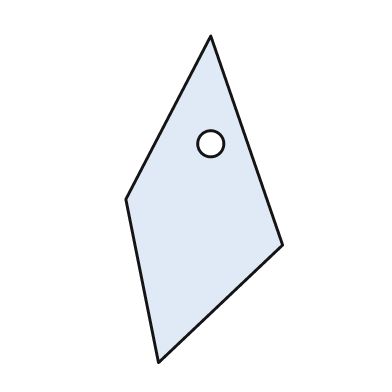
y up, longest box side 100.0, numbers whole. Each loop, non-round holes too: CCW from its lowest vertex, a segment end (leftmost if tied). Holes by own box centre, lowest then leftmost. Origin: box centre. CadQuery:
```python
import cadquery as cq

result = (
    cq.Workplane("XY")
    .moveTo(-14.0, -50.0)
    .lineTo(24.0, -14.0)
    .lineTo(2.0, 50.0)
    .lineTo(-24.0, 0.0)
    .close()
    .moveTo(2.0, 17.0)
    .circle(4.0)
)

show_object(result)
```